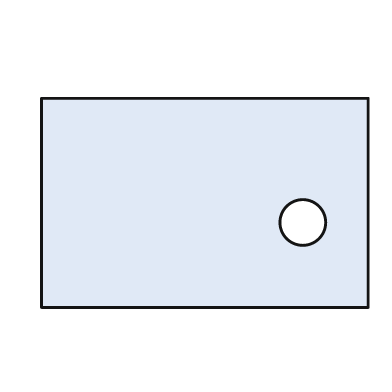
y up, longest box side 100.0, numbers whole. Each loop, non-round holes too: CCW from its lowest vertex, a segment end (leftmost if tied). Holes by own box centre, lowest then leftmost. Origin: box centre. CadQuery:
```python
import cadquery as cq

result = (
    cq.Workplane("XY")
    .moveTo(-50.0, -32.0)
    .lineTo(50.0, -32.0)
    .lineTo(50.0, 32.0)
    .lineTo(-50.0, 32.0)
    .close()
    .moveTo(30.0, -6.0)
    .circle(7.0)
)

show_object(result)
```